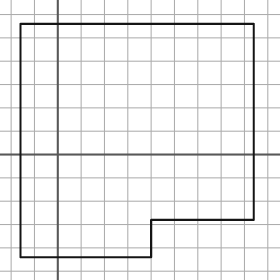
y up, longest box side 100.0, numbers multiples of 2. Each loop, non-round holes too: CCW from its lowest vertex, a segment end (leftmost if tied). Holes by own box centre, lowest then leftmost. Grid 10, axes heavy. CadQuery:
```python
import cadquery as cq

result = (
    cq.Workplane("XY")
    .moveTo(-16.0, -44.0)
    .lineTo(40.0, -44.0)
    .lineTo(40.0, -28.0)
    .lineTo(84.0, -28.0)
    .lineTo(84.0, 56.0)
    .lineTo(-16.0, 56.0)
    .close()
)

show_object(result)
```